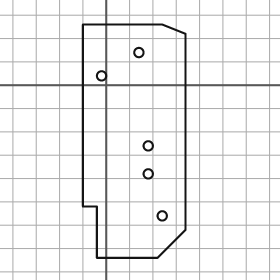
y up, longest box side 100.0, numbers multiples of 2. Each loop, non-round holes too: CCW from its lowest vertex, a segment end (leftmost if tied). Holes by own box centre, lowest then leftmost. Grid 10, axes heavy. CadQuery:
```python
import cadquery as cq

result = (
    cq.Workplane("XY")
    .moveTo(-4.0, -74.0)
    .lineTo(22.0, -74.0)
    .lineTo(34.0, -62.0)
    .lineTo(34.0, 22.0)
    .lineTo(24.0, 26.0)
    .lineTo(-10.0, 26.0)
    .lineTo(-10.0, -52.0)
    .lineTo(-4.0, -52.0)
    .close()
    .moveTo(24.0, -56.0)
    .circle(2.0)
    .moveTo(18.0, -38.0)
    .circle(2.0)
    .moveTo(18.0, -26.0)
    .circle(2.0)
    .moveTo(-2.0, 4.0)
    .circle(2.0)
    .moveTo(14.0, 14.0)
    .circle(2.0)
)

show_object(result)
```